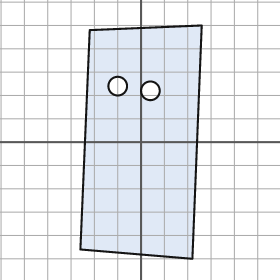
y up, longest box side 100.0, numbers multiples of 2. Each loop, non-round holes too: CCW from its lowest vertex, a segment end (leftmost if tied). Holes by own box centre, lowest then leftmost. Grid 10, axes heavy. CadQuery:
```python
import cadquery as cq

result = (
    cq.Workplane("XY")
    .moveTo(22.0, -50.0)
    .lineTo(26.0, 50.0)
    .lineTo(-22.0, 48.0)
    .lineTo(-26.0, -46.0)
    .close()
    .moveTo(4.0, 22.0)
    .circle(4.0)
    .moveTo(-10.0, 24.0)
    .circle(4.0)
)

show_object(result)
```